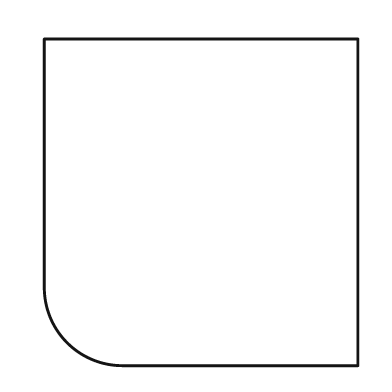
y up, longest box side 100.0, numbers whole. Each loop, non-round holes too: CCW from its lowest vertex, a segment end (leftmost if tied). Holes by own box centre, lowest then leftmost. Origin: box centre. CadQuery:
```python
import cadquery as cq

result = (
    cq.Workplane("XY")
    .moveTo(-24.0, -50.0)
    .lineTo(48.0, -50.0)
    .lineTo(48.0, 50.0)
    .lineTo(-48.0, 50.0)
    .lineTo(-48.0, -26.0)
    .threePointArc((-41.0, -43.0), (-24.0, -50.0))
    .close()
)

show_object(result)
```